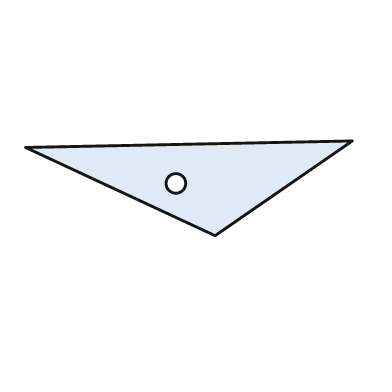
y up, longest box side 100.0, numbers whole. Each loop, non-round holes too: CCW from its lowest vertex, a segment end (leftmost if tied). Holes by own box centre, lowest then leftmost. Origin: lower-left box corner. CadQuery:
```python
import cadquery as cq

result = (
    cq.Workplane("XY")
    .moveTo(58.0, 0.0)
    .lineTo(100.0, 29.0)
    .lineTo(0.0, 27.0)
    .close()
    .moveTo(46.0, 16.0)
    .circle(3.0)
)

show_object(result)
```